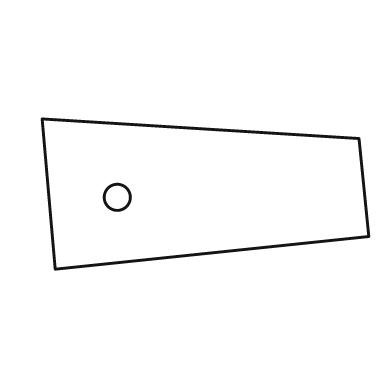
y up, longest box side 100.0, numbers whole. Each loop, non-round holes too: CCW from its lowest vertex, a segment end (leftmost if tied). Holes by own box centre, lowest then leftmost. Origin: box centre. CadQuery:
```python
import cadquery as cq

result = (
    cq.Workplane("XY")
    .moveTo(-46.0, -23.0)
    .lineTo(50.0, -13.0)
    .lineTo(47.0, 17.0)
    .lineTo(-50.0, 23.0)
    .close()
    .moveTo(-27.0, -1.0)
    .circle(4.0)
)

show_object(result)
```